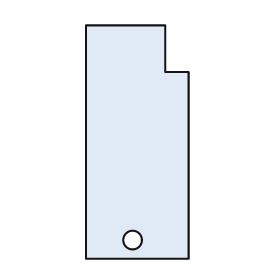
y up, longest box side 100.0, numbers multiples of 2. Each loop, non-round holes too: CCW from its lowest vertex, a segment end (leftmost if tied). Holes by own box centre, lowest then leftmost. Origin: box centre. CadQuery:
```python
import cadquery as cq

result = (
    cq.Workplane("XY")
    .moveTo(-22.0, -50.0)
    .lineTo(22.0, -50.0)
    .lineTo(22.0, 30.0)
    .lineTo(12.0, 30.0)
    .lineTo(12.0, 50.0)
    .lineTo(-22.0, 50.0)
    .close()
    .moveTo(-2.0, -42.0)
    .circle(4.0)
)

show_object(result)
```